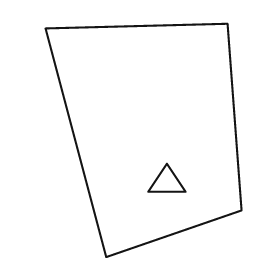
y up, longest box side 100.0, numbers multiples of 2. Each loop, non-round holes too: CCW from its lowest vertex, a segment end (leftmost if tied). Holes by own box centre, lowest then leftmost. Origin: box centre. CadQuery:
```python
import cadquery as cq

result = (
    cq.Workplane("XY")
    .moveTo(-16.0, -50.0)
    .lineTo(42.0, -30.0)
    .lineTo(36.0, 50.0)
    .lineTo(-42.0, 48.0)
    .close()
    .moveTo(2.0, -22.0)
    .lineTo(18.0, -22.0)
    .lineTo(10.0, -10.0)
    .close()
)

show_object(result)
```